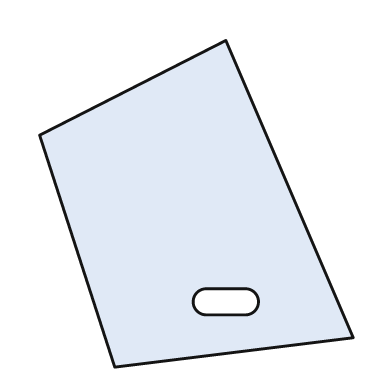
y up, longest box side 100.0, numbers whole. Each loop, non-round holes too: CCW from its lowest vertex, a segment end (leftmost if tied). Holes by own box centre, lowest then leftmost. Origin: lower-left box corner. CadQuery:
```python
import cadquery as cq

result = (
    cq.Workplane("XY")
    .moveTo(23.0, 0.0)
    .lineTo(96.0, 9.0)
    .lineTo(57.0, 100.0)
    .lineTo(0.0, 71.0)
    .close()
    .moveTo(51.0, 16.0)
    .lineTo(63.0, 16.0)
    .threePointArc((67.0, 20.0), (63.0, 24.0))
    .lineTo(51.0, 24.0)
    .threePointArc((47.0, 20.0), (51.0, 16.0))
    .close()
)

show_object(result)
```